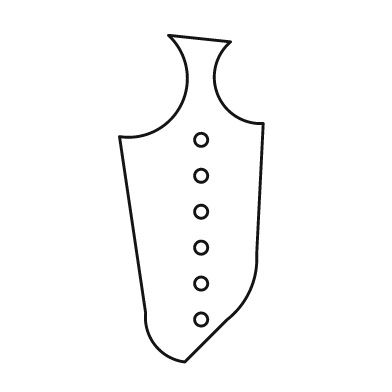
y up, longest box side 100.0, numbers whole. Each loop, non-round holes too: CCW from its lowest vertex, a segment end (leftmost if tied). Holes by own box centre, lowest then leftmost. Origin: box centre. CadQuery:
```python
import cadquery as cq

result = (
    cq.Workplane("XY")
    .moveTo(-2.0, -50.0)
    .lineTo(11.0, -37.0)
    .threePointArc((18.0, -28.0), (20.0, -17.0))
    .lineTo(22.0, 23.0)
    .threePointArc((8.0, 32.0), (12.0, 48.0))
    .lineTo(-7.0, 50.0)
    .threePointArc((-3.0, 29.0), (-22.0, 19.0))
    .lineTo(-14.0, -35.0)
    .threePointArc((-11.0, -45.0), (-2.0, -50.0))
    .close()
    .moveTo(3.0, -37.0)
    .circle(2.0)
    .moveTo(3.0, -26.0)
    .circle(2.0)
    .moveTo(3.0, -15.0)
    .circle(2.0)
    .moveTo(3.0, -4.0)
    .circle(2.0)
    .moveTo(3.0, 7.0)
    .circle(2.0)
    .moveTo(3.0, 18.0)
    .circle(2.0)
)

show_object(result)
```